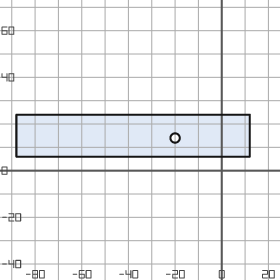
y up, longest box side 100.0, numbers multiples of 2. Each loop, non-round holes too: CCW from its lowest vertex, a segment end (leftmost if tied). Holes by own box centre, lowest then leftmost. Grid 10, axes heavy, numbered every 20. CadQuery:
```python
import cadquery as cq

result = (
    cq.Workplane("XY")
    .moveTo(-88.0, 6.0)
    .lineTo(12.0, 6.0)
    .lineTo(12.0, 24.0)
    .lineTo(-88.0, 24.0)
    .close()
    .moveTo(-20.0, 14.0)
    .circle(2.0)
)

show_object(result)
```